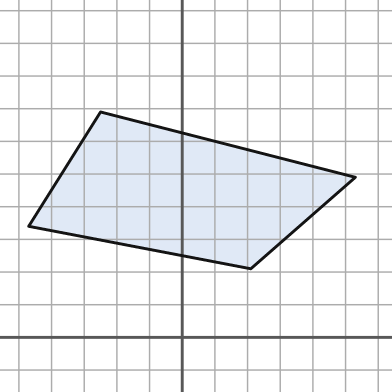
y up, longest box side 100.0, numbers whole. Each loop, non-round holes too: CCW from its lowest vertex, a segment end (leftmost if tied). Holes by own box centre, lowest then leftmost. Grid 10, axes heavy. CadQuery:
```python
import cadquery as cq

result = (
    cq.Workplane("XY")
    .moveTo(21.0, 21.0)
    .lineTo(53.0, 49.0)
    .lineTo(-25.0, 69.0)
    .lineTo(-47.0, 34.0)
    .close()
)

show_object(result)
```